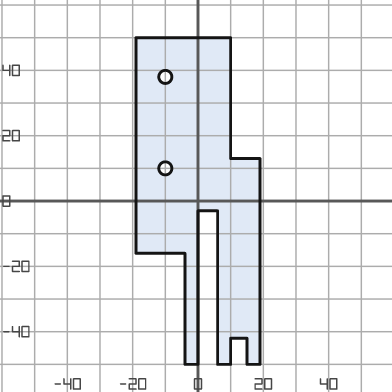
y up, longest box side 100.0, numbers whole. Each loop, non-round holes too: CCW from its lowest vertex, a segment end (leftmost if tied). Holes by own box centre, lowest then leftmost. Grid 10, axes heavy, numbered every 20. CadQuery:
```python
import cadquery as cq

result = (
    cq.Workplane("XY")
    .moveTo(-4.0, -50.0)
    .lineTo(0.0, -50.0)
    .lineTo(0.0, -3.0)
    .lineTo(6.0, -3.0)
    .lineTo(6.0, -50.0)
    .lineTo(10.0, -50.0)
    .lineTo(10.0, -42.0)
    .lineTo(15.0, -42.0)
    .lineTo(15.0, -50.0)
    .lineTo(19.0, -50.0)
    .lineTo(19.0, 13.0)
    .lineTo(10.0, 13.0)
    .lineTo(10.0, 50.0)
    .lineTo(-19.0, 50.0)
    .lineTo(-19.0, -16.0)
    .lineTo(-4.0, -16.0)
    .close()
    .moveTo(-10.0, 10.0)
    .circle(2.0)
    .moveTo(-10.0, 38.0)
    .circle(2.0)
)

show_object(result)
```